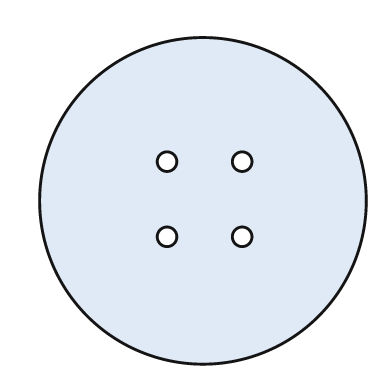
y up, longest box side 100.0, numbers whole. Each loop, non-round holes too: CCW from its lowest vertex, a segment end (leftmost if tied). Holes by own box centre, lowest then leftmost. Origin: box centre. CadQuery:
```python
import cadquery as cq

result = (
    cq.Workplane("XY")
    .moveTo(0.0, 0.0)
    .circle(50.0)
    .moveTo(-11.0, -11.0)
    .circle(3.0)
    .moveTo(12.0, -11.0)
    .circle(3.0)
    .moveTo(-11.0, 12.0)
    .circle(3.0)
    .moveTo(12.0, 12.0)
    .circle(3.0)
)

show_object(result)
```